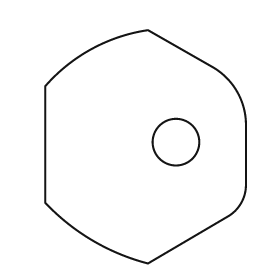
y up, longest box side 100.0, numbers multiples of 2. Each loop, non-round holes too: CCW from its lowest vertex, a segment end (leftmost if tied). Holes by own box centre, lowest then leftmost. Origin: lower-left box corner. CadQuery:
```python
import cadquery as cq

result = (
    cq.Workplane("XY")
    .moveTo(44.0, 0.0)
    .lineTo(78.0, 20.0)
    .threePointArc((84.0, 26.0), (86.0, 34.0))
    .lineTo(86.0, 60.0)
    .threePointArc((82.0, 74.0), (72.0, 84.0))
    .lineTo(44.0, 100.0)
    .threePointArc((20.0, 92.0), (0.0, 76.0))
    .lineTo(0.0, 26.0)
    .threePointArc((20.0, 10.0), (44.0, 0.0))
    .close()
    .moveTo(56.0, 52.0)
    .circle(10.0)
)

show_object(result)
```